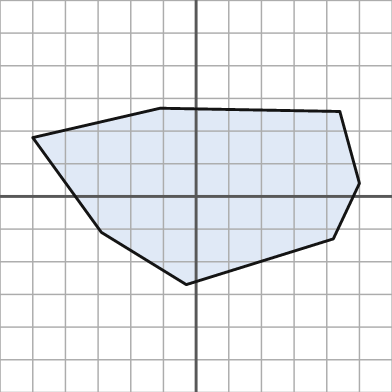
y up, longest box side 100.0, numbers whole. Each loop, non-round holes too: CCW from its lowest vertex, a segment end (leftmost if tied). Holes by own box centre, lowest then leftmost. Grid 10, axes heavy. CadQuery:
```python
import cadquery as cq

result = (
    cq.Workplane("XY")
    .moveTo(-3.0, -27.0)
    .lineTo(42.0, -13.0)
    .lineTo(50.0, 4.0)
    .lineTo(44.0, 26.0)
    .lineTo(-11.0, 27.0)
    .lineTo(-50.0, 18.0)
    .lineTo(-29.0, -11.0)
    .close()
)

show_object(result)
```